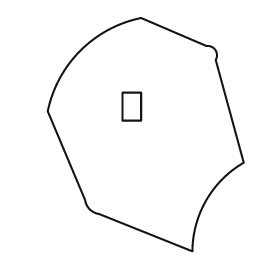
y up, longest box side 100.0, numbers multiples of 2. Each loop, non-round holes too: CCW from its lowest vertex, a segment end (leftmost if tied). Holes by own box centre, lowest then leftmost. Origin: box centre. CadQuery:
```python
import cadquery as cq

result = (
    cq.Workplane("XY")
    .moveTo(20.0, -50.0)
    .threePointArc((26.0, -28.0), (42.0, -12.0))
    .lineTo(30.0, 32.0)
    .threePointArc((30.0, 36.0), (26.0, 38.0))
    .lineTo(-2.0, 50.0)
    .threePointArc((-28.0, 36.0), (-42.0, 10.0))
    .lineTo(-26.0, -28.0)
    .threePointArc((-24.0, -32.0), (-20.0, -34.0))
    .close()
    .moveTo(-10.0, 6.0)
    .lineTo(-2.0, 6.0)
    .lineTo(-2.0, 18.0)
    .lineTo(-10.0, 18.0)
    .close()
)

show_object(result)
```